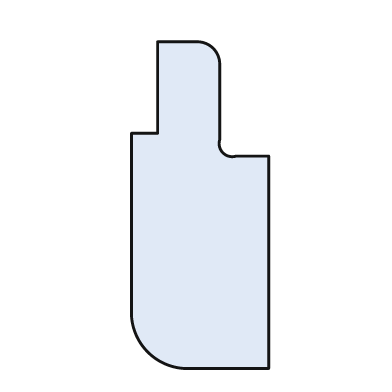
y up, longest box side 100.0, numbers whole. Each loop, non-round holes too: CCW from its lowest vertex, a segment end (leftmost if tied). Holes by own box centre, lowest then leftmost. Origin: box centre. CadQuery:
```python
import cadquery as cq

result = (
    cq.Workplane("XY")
    .moveTo(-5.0, -50.0)
    .lineTo(21.0, -50.0)
    .lineTo(21.0, 15.0)
    .lineTo(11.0, 15.0)
    .threePointArc((7.0, 16.0), (6.0, 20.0))
    .lineTo(6.0, 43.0)
    .threePointArc((4.0, 48.0), (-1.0, 50.0))
    .lineTo(-13.0, 50.0)
    .lineTo(-13.0, 22.0)
    .lineTo(-21.0, 22.0)
    .lineTo(-21.0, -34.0)
    .threePointArc((-16.0, -45.0), (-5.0, -50.0))
    .close()
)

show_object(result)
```